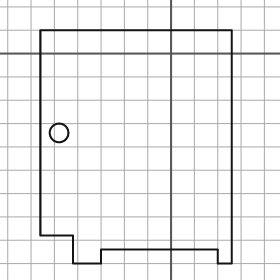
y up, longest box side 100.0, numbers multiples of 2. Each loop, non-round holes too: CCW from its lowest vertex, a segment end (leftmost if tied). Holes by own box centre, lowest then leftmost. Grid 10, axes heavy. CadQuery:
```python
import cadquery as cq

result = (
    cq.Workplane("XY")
    .moveTo(-42.0, -90.0)
    .lineTo(-30.0, -90.0)
    .lineTo(-30.0, -84.0)
    .lineTo(20.0, -84.0)
    .lineTo(20.0, -90.0)
    .lineTo(26.0, -90.0)
    .lineTo(26.0, 10.0)
    .lineTo(-56.0, 10.0)
    .lineTo(-56.0, -78.0)
    .lineTo(-42.0, -78.0)
    .close()
    .moveTo(-48.0, -34.0)
    .circle(4.0)
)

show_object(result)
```